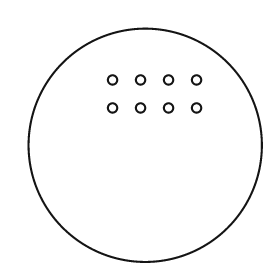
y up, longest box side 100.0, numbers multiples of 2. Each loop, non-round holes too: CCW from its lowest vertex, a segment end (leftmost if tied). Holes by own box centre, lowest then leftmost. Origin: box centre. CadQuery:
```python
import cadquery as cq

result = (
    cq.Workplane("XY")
    .moveTo(0.0, 0.0)
    .circle(50.0)
    .moveTo(-14.0, 16.0)
    .circle(2.0)
    .moveTo(-2.0, 16.0)
    .circle(2.0)
    .moveTo(10.0, 16.0)
    .circle(2.0)
    .moveTo(22.0, 16.0)
    .circle(2.0)
    .moveTo(-14.0, 28.0)
    .circle(2.0)
    .moveTo(-2.0, 28.0)
    .circle(2.0)
    .moveTo(10.0, 28.0)
    .circle(2.0)
    .moveTo(22.0, 28.0)
    .circle(2.0)
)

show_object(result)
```